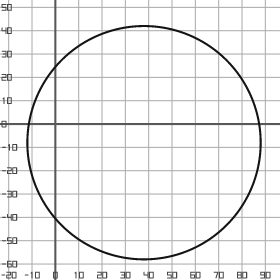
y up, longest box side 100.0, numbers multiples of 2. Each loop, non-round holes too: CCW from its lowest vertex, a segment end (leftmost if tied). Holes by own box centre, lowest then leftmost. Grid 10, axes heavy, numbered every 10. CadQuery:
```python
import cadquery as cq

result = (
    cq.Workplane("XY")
    .moveTo(38.0, -8.0)
    .circle(50.0)
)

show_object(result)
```